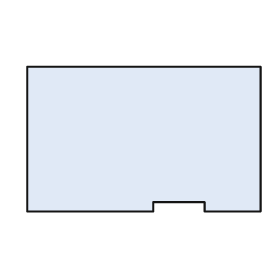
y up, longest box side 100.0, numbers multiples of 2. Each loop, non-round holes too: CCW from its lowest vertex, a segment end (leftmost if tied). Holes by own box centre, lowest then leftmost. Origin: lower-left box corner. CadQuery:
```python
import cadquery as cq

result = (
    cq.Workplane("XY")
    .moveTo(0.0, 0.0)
    .lineTo(54.0, 0.0)
    .lineTo(54.0, 4.0)
    .lineTo(76.0, 4.0)
    .lineTo(76.0, 0.0)
    .lineTo(100.0, 0.0)
    .lineTo(100.0, 62.0)
    .lineTo(0.0, 62.0)
    .close()
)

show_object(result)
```